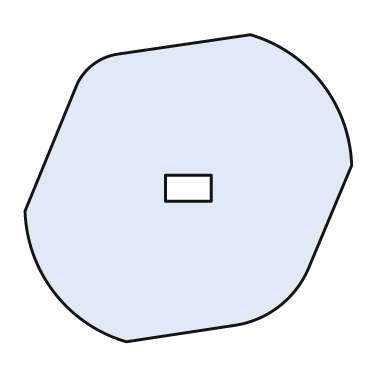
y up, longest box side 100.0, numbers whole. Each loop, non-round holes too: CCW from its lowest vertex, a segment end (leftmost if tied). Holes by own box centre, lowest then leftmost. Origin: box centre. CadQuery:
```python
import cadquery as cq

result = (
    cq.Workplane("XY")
    .moveTo(-19.0, -47.0)
    .lineTo(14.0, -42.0)
    .threePointArc((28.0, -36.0), (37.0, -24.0))
    .lineTo(50.0, 7.0)
    .threePointArc((41.0, 32.0), (19.0, 47.0))
    .lineTo(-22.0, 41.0)
    .threePointArc((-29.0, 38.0), (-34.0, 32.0))
    .lineTo(-50.0, -7.0)
    .threePointArc((-41.0, -32.0), (-19.0, -47.0))
    .close()
    .moveTo(-7.0, -4.0)
    .lineTo(7.0, -4.0)
    .lineTo(7.0, 4.0)
    .lineTo(-7.0, 4.0)
    .close()
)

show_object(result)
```